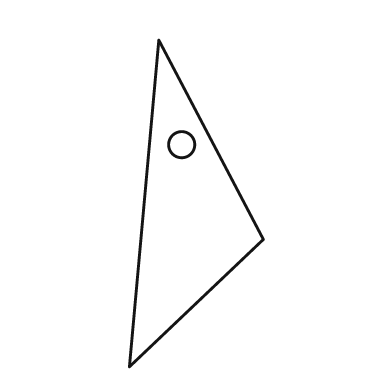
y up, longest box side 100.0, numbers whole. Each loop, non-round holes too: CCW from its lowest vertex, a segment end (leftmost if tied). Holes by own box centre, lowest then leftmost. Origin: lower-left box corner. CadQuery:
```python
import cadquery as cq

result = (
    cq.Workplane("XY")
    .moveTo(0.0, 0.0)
    .lineTo(41.0, 39.0)
    .lineTo(9.0, 100.0)
    .close()
    .moveTo(16.0, 68.0)
    .circle(4.0)
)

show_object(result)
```